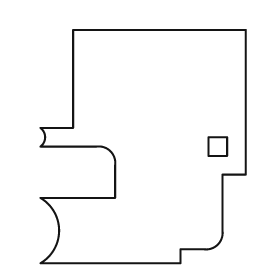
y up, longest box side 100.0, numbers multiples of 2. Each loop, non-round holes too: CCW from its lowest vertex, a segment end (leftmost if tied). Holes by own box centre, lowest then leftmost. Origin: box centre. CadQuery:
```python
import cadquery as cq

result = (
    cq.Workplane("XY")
    .moveTo(-44.0, -50.0)
    .lineTo(16.0, -50.0)
    .lineTo(16.0, -44.0)
    .lineTo(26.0, -44.0)
    .threePointArc((32.0, -42.0), (34.0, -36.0))
    .lineTo(34.0, -12.0)
    .lineTo(44.0, -12.0)
    .lineTo(44.0, 50.0)
    .lineTo(-30.0, 50.0)
    .lineTo(-30.0, 8.0)
    .lineTo(-44.0, 8.0)
    .threePointArc((-42.0, 4.0), (-44.0, 0.0))
    .lineTo(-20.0, 0.0)
    .threePointArc((-14.0, -2.0), (-12.0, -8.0))
    .lineTo(-12.0, -22.0)
    .lineTo(-44.0, -22.0)
    .threePointArc((-36.0, -36.0), (-44.0, -50.0))
    .close()
    .moveTo(28.0, -4.0)
    .lineTo(36.0, -4.0)
    .lineTo(36.0, 4.0)
    .lineTo(28.0, 4.0)
    .close()
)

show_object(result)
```